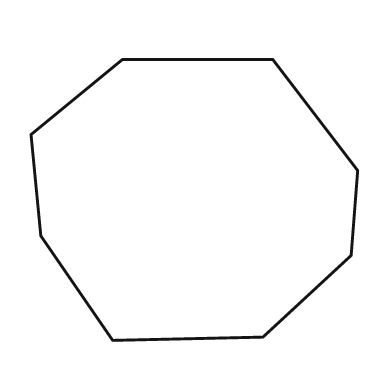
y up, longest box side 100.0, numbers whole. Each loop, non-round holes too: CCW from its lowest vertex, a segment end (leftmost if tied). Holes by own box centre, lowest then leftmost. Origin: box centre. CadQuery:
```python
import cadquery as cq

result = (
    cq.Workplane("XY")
    .moveTo(-25.0, -43.0)
    .lineTo(21.0, -42.0)
    .lineTo(48.0, -17.0)
    .lineTo(50.0, 9.0)
    .lineTo(24.0, 43.0)
    .lineTo(-22.0, 43.0)
    .lineTo(-50.0, 20.0)
    .lineTo(-47.0, -11.0)
    .close()
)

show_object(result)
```